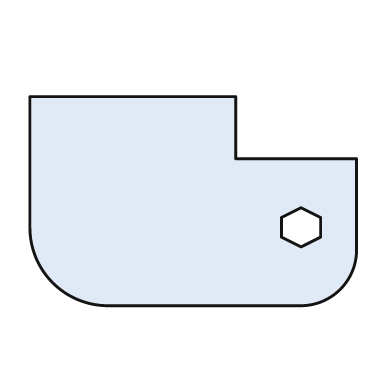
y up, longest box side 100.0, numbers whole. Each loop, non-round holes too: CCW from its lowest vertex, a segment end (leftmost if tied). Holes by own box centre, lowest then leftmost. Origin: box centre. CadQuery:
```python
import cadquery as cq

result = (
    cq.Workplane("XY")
    .moveTo(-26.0, -32.0)
    .lineTo(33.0, -32.0)
    .threePointArc((45.0, -27.0), (50.0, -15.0))
    .lineTo(50.0, 13.0)
    .lineTo(13.0, 13.0)
    .lineTo(13.0, 32.0)
    .lineTo(-50.0, 32.0)
    .lineTo(-50.0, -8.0)
    .threePointArc((-43.0, -25.0), (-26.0, -32.0))
    .close()
    .moveTo(33.0, -14.0)
    .lineTo(39.0, -11.0)
    .lineTo(39.0, -5.0)
    .lineTo(33.0, -2.0)
    .lineTo(27.0, -5.0)
    .lineTo(27.0, -11.0)
    .close()
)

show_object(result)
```